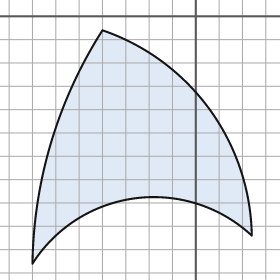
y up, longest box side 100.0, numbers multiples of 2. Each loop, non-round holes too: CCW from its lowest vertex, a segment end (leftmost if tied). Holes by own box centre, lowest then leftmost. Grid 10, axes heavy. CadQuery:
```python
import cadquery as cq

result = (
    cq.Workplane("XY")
    .moveTo(-70.0, -106.0)
    .threePointArc((-26.0, -78.0), (24.0, -94.0))
    .threePointArc((6.0, -40.0), (-40.0, -6.0))
    .threePointArc((-62.0, -54.0), (-70.0, -106.0))
    .close()
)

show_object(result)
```